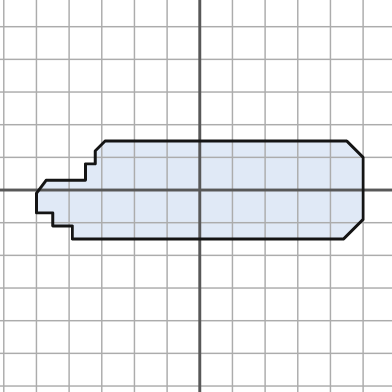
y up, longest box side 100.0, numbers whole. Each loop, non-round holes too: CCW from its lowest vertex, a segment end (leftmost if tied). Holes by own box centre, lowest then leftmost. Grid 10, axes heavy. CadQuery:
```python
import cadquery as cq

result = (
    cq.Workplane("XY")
    .moveTo(-39.0, -15.0)
    .lineTo(44.0, -15.0)
    .lineTo(50.0, -9.0)
    .lineTo(50.0, 10.0)
    .lineTo(45.0, 15.0)
    .lineTo(-29.0, 15.0)
    .lineTo(-32.0, 12.0)
    .lineTo(-32.0, 8.0)
    .lineTo(-35.0, 8.0)
    .lineTo(-35.0, 3.0)
    .lineTo(-47.0, 3.0)
    .lineTo(-50.0, -1.0)
    .lineTo(-50.0, -7.0)
    .lineTo(-45.0, -7.0)
    .lineTo(-45.0, -11.0)
    .lineTo(-39.0, -11.0)
    .close()
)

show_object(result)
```